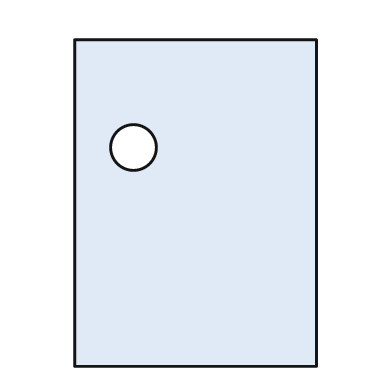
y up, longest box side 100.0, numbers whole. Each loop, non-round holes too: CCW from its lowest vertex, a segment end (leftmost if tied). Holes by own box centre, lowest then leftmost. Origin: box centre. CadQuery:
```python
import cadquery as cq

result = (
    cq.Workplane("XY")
    .moveTo(-37.0, -50.0)
    .lineTo(37.0, -50.0)
    .lineTo(37.0, 50.0)
    .lineTo(-37.0, 50.0)
    .close()
    .moveTo(-19.0, 17.0)
    .circle(7.0)
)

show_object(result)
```